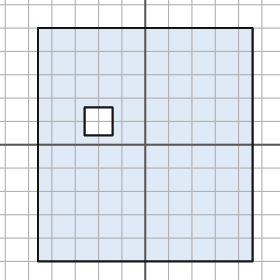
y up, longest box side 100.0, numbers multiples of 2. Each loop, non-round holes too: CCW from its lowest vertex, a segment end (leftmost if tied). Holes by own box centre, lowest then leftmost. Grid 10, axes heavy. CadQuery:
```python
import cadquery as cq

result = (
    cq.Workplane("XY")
    .moveTo(-46.0, -50.0)
    .lineTo(46.0, -50.0)
    .lineTo(46.0, 50.0)
    .lineTo(-46.0, 50.0)
    .close()
    .moveTo(-26.0, 4.0)
    .lineTo(-14.0, 4.0)
    .lineTo(-14.0, 16.0)
    .lineTo(-26.0, 16.0)
    .close()
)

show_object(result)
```